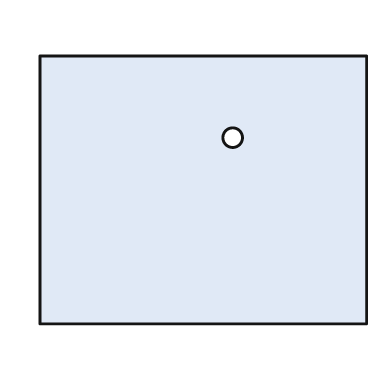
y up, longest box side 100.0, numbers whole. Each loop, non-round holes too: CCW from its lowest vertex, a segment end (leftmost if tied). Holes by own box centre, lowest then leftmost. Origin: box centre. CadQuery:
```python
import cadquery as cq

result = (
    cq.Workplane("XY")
    .moveTo(-50.0, -41.0)
    .lineTo(50.0, -41.0)
    .lineTo(50.0, 41.0)
    .lineTo(-50.0, 41.0)
    .close()
    .moveTo(9.0, 16.0)
    .circle(3.0)
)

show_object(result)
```